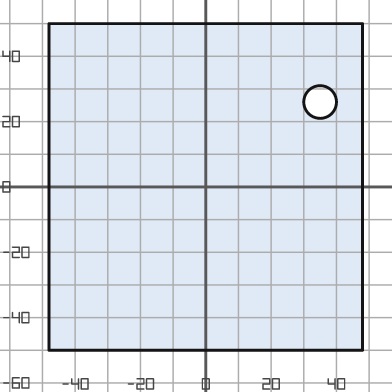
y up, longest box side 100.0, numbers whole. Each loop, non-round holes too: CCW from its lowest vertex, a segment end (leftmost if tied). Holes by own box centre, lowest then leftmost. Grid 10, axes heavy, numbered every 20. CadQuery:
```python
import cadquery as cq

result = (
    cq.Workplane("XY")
    .moveTo(-48.0, -50.0)
    .lineTo(48.0, -50.0)
    .lineTo(48.0, 50.0)
    .lineTo(-48.0, 50.0)
    .close()
    .moveTo(35.0, 26.0)
    .circle(5.0)
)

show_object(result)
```